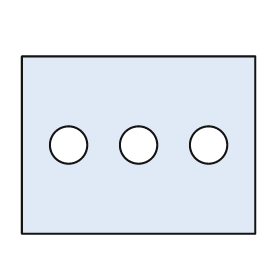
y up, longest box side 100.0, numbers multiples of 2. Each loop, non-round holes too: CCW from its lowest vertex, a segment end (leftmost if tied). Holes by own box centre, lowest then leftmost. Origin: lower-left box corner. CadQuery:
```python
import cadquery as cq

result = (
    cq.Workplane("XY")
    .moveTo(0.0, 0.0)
    .lineTo(100.0, 0.0)
    .lineTo(100.0, 76.0)
    .lineTo(0.0, 76.0)
    .close()
    .moveTo(20.0, 38.0)
    .circle(8.0)
    .moveTo(50.0, 38.0)
    .circle(8.0)
    .moveTo(80.0, 38.0)
    .circle(8.0)
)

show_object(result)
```